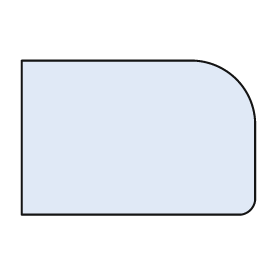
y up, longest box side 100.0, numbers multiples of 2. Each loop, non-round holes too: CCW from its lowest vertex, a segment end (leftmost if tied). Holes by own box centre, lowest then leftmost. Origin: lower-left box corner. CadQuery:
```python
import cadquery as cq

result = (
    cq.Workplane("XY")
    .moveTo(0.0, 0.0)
    .lineTo(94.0, 0.0)
    .threePointArc((98.0, 2.0), (100.0, 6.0))
    .lineTo(100.0, 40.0)
    .threePointArc((92.0, 58.0), (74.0, 66.0))
    .lineTo(0.0, 66.0)
    .close()
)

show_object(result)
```